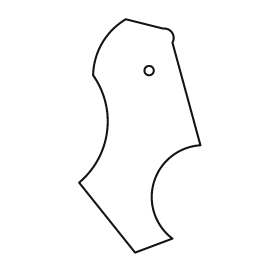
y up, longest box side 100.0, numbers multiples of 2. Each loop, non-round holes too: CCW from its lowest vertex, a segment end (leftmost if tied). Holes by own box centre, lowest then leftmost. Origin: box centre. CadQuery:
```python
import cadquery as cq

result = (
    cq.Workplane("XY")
    .moveTo(-2.0, -50.0)
    .lineTo(14.0, -44.0)
    .threePointArc((6.0, -20.0), (26.0, -4.0))
    .lineTo(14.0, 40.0)
    .threePointArc((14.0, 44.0), (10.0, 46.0))
    .lineTo(-6.0, 50.0)
    .threePointArc((-16.0, 40.0), (-20.0, 26.0))
    .threePointArc((-14.0, 2.0), (-26.0, -20.0))
    .close()
    .moveTo(4.0, 28.0)
    .circle(2.0)
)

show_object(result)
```